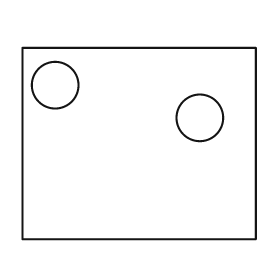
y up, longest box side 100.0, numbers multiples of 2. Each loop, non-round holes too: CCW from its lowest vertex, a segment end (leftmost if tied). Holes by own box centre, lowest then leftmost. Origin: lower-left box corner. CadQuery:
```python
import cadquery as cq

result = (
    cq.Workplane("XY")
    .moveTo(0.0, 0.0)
    .lineTo(100.0, 0.0)
    .lineTo(100.0, 82.0)
    .lineTo(0.0, 82.0)
    .close()
    .moveTo(76.0, 52.0)
    .circle(10.0)
    .moveTo(14.0, 66.0)
    .circle(10.0)
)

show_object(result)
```